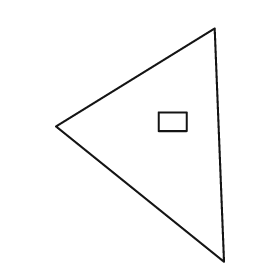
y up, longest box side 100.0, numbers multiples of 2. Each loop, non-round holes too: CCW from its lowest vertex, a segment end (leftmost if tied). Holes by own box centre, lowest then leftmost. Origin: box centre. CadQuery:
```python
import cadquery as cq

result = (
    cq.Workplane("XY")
    .moveTo(36.0, -50.0)
    .lineTo(32.0, 50.0)
    .lineTo(-36.0, 8.0)
    .close()
    .moveTo(8.0, 6.0)
    .lineTo(20.0, 6.0)
    .lineTo(20.0, 14.0)
    .lineTo(8.0, 14.0)
    .close()
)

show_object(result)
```